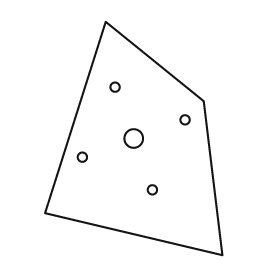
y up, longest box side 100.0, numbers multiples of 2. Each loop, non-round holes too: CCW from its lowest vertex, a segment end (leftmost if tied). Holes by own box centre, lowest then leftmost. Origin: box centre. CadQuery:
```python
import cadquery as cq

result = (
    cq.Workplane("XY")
    .moveTo(38.0, -50.0)
    .lineTo(30.0, 16.0)
    .lineTo(-12.0, 50.0)
    .lineTo(-38.0, -32.0)
    .close()
    .moveTo(8.0, -22.0)
    .circle(2.0)
    .moveTo(-22.0, -8.0)
    .circle(2.0)
    .moveTo(0.0, 0.0)
    .circle(4.0)
    .moveTo(22.0, 8.0)
    .circle(2.0)
    .moveTo(-8.0, 22.0)
    .circle(2.0)
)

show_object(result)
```